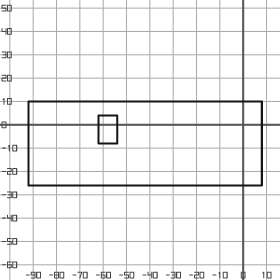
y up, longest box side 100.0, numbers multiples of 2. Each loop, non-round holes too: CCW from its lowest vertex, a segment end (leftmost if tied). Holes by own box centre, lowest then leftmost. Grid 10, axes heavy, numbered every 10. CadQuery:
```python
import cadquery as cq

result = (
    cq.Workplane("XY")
    .moveTo(-92.0, -26.0)
    .lineTo(8.0, -26.0)
    .lineTo(8.0, 10.0)
    .lineTo(-92.0, 10.0)
    .close()
    .moveTo(-62.0, -8.0)
    .lineTo(-54.0, -8.0)
    .lineTo(-54.0, 4.0)
    .lineTo(-62.0, 4.0)
    .close()
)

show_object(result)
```